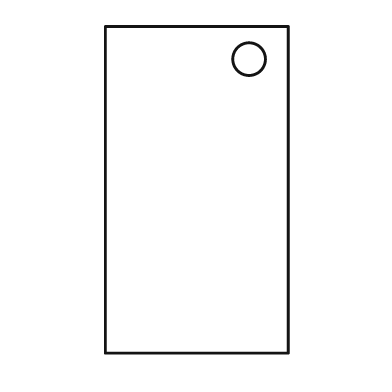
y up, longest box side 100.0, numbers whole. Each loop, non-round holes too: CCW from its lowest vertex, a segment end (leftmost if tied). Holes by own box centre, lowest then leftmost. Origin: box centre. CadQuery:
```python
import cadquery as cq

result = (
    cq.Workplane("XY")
    .moveTo(-28.0, -50.0)
    .lineTo(28.0, -50.0)
    .lineTo(28.0, 50.0)
    .lineTo(-28.0, 50.0)
    .close()
    .moveTo(16.0, 40.0)
    .circle(5.0)
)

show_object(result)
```